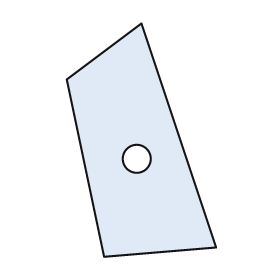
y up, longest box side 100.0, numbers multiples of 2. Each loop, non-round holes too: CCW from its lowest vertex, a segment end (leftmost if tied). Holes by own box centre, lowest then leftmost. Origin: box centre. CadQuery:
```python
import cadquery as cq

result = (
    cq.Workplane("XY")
    .moveTo(-16.0, -50.0)
    .lineTo(32.0, -46.0)
    .lineTo(0.0, 50.0)
    .lineTo(-32.0, 26.0)
    .close()
    .moveTo(-2.0, -8.0)
    .circle(6.0)
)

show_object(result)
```